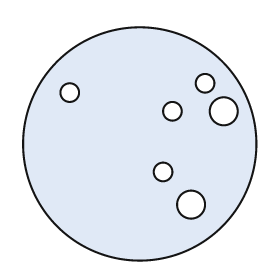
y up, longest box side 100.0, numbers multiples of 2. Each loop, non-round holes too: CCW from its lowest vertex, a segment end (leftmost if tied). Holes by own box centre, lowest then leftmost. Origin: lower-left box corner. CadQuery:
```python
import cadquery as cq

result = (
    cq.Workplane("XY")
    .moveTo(50.0, 50.0)
    .circle(50.0)
    .moveTo(72.0, 24.0)
    .circle(6.0)
    .moveTo(60.0, 38.0)
    .circle(4.0)
    .moveTo(64.0, 64.0)
    .circle(4.0)
    .moveTo(86.0, 64.0)
    .circle(6.0)
    .moveTo(20.0, 72.0)
    .circle(4.0)
    .moveTo(78.0, 76.0)
    .circle(4.0)
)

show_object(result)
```